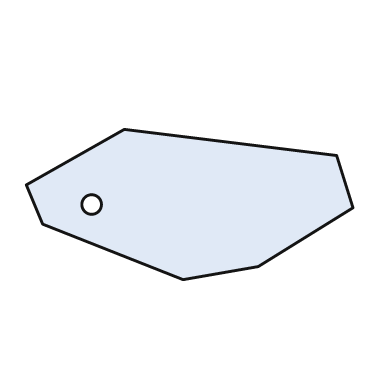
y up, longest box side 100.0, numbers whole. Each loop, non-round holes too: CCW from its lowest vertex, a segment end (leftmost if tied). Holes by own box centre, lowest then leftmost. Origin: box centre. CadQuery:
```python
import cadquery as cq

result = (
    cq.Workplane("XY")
    .moveTo(-2.0, -23.0)
    .lineTo(21.0, -19.0)
    .lineTo(50.0, -1.0)
    .lineTo(45.0, 15.0)
    .lineTo(-20.0, 23.0)
    .lineTo(-50.0, 6.0)
    .lineTo(-45.0, -6.0)
    .close()
    .moveTo(-30.0, 0.0)
    .circle(3.0)
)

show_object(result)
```